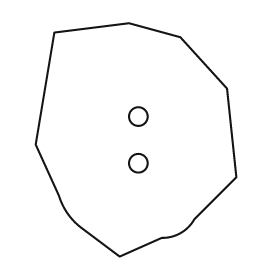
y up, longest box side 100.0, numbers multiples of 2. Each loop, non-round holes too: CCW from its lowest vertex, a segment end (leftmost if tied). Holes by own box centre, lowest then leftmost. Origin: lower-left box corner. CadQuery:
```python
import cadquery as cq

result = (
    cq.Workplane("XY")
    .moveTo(36.0, 0.0)
    .lineTo(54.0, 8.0)
    .threePointArc((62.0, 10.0), (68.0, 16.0))
    .lineTo(86.0, 34.0)
    .lineTo(82.0, 72.0)
    .lineTo(62.0, 94.0)
    .lineTo(40.0, 100.0)
    .lineTo(8.0, 96.0)
    .lineTo(0.0, 48.0)
    .lineTo(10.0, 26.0)
    .threePointArc((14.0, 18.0), (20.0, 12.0))
    .close()
    .moveTo(44.0, 40.0)
    .circle(4.0)
    .moveTo(44.0, 60.0)
    .circle(4.0)
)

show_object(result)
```